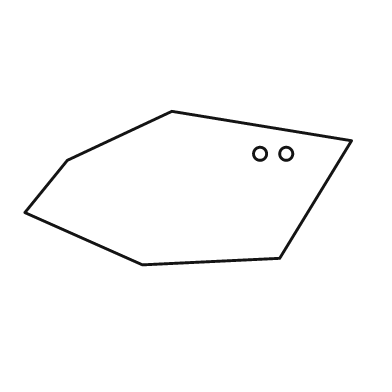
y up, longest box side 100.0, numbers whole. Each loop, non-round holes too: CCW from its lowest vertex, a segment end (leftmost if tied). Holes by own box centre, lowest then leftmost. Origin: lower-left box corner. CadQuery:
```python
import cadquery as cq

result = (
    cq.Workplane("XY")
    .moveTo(36.0, 0.0)
    .lineTo(78.0, 2.0)
    .lineTo(100.0, 38.0)
    .lineTo(45.0, 47.0)
    .lineTo(13.0, 32.0)
    .lineTo(0.0, 16.0)
    .close()
    .moveTo(72.0, 34.0)
    .circle(2.0)
    .moveTo(80.0, 34.0)
    .circle(2.0)
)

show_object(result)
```